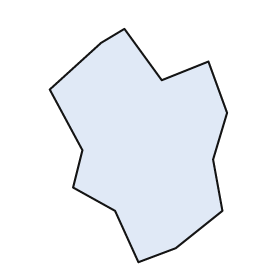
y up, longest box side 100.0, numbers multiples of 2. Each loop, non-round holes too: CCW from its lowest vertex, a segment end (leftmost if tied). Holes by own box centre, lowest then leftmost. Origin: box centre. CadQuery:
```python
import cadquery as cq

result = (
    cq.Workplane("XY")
    .moveTo(0.0, -50.0)
    .lineTo(16.0, -44.0)
    .lineTo(36.0, -28.0)
    .lineTo(32.0, -6.0)
    .lineTo(38.0, 14.0)
    .lineTo(30.0, 36.0)
    .lineTo(10.0, 28.0)
    .lineTo(-6.0, 50.0)
    .lineTo(-16.0, 44.0)
    .lineTo(-38.0, 24.0)
    .lineTo(-24.0, -2.0)
    .lineTo(-28.0, -18.0)
    .lineTo(-10.0, -28.0)
    .close()
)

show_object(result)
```